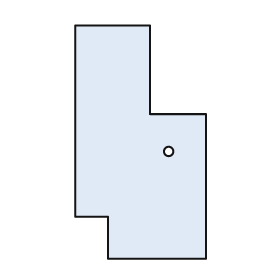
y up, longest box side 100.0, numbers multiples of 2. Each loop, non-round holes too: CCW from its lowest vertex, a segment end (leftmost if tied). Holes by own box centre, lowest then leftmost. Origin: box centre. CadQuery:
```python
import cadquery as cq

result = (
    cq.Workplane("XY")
    .moveTo(-14.0, -50.0)
    .lineTo(28.0, -50.0)
    .lineTo(28.0, 12.0)
    .lineTo(4.0, 12.0)
    .lineTo(4.0, 50.0)
    .lineTo(-28.0, 50.0)
    .lineTo(-28.0, -32.0)
    .lineTo(-14.0, -32.0)
    .close()
    .moveTo(12.0, -4.0)
    .circle(2.0)
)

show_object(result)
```